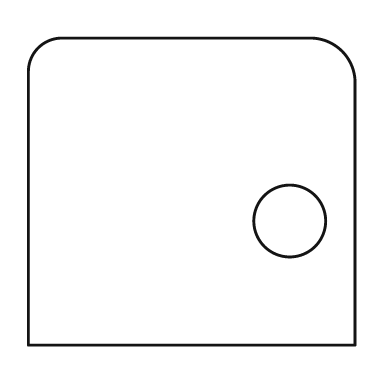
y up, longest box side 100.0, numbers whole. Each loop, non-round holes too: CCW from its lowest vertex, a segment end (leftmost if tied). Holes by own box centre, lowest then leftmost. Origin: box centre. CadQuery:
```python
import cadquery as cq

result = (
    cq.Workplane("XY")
    .moveTo(-50.0, -47.0)
    .lineTo(50.0, -47.0)
    .lineTo(50.0, 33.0)
    .threePointArc((46.0, 43.0), (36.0, 47.0))
    .lineTo(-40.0, 47.0)
    .threePointArc((-47.0, 44.0), (-50.0, 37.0))
    .close()
    .moveTo(30.0, -9.0)
    .circle(11.0)
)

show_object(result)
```